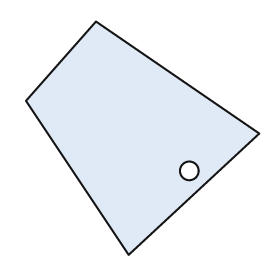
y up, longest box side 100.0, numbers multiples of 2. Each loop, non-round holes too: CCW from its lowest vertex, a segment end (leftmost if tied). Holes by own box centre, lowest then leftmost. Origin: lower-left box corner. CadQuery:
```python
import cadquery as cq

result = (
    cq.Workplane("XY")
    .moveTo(44.0, 0.0)
    .lineTo(100.0, 52.0)
    .lineTo(30.0, 100.0)
    .lineTo(0.0, 66.0)
    .close()
    .moveTo(70.0, 36.0)
    .circle(4.0)
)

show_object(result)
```